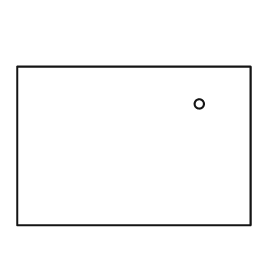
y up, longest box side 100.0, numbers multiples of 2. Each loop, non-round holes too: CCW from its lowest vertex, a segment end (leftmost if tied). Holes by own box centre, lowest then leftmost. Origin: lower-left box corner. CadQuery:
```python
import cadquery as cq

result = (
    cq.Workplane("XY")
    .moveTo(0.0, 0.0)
    .lineTo(100.0, 0.0)
    .lineTo(100.0, 68.0)
    .lineTo(0.0, 68.0)
    .close()
    .moveTo(78.0, 52.0)
    .circle(2.0)
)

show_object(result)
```